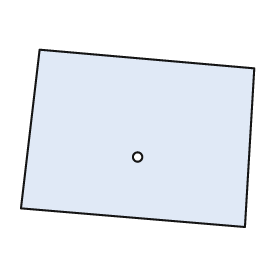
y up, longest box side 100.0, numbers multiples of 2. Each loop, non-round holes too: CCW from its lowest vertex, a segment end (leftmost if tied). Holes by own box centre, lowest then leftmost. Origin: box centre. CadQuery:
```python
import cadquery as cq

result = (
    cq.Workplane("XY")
    .moveTo(46.0, -38.0)
    .lineTo(50.0, 30.0)
    .lineTo(-42.0, 38.0)
    .lineTo(-50.0, -30.0)
    .close()
    .moveTo(0.0, -8.0)
    .circle(2.0)
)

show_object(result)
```